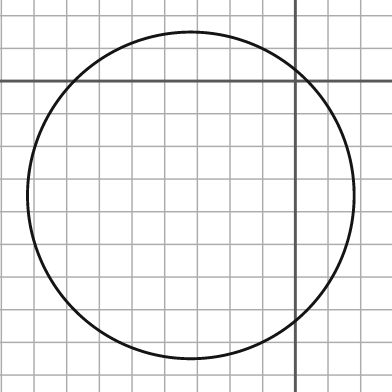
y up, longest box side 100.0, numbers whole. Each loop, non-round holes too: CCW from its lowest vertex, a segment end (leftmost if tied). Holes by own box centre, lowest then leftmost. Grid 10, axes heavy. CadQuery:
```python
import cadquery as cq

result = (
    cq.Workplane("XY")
    .moveTo(-32.0, -35.0)
    .circle(50.0)
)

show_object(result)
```